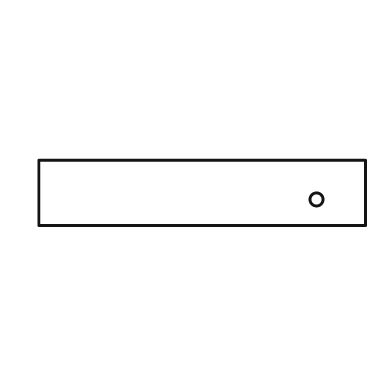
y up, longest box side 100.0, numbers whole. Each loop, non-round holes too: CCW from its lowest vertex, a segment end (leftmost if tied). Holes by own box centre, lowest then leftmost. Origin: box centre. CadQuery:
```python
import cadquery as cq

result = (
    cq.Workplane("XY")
    .moveTo(-50.0, -10.0)
    .lineTo(50.0, -10.0)
    .lineTo(50.0, 10.0)
    .lineTo(-50.0, 10.0)
    .close()
    .moveTo(35.0, -2.0)
    .circle(2.0)
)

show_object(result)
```